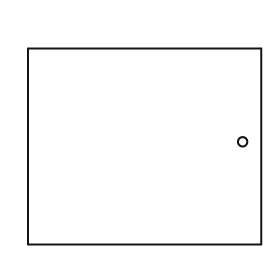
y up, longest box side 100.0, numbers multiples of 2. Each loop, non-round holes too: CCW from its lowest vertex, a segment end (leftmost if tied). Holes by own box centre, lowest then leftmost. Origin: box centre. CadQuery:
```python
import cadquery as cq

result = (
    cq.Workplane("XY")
    .moveTo(-50.0, -42.0)
    .lineTo(50.0, -42.0)
    .lineTo(50.0, 42.0)
    .lineTo(-50.0, 42.0)
    .close()
    .moveTo(42.0, 2.0)
    .circle(2.0)
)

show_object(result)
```